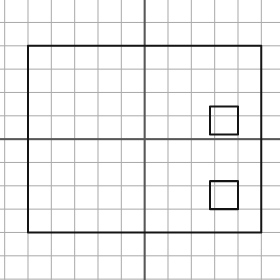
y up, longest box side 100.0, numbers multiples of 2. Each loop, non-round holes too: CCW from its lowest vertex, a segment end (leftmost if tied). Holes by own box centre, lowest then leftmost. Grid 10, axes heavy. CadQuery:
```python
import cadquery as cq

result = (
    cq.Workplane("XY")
    .moveTo(-50.0, -40.0)
    .lineTo(50.0, -40.0)
    .lineTo(50.0, 40.0)
    .lineTo(-50.0, 40.0)
    .close()
    .moveTo(28.0, -30.0)
    .lineTo(40.0, -30.0)
    .lineTo(40.0, -18.0)
    .lineTo(28.0, -18.0)
    .close()
    .moveTo(28.0, 2.0)
    .lineTo(40.0, 2.0)
    .lineTo(40.0, 14.0)
    .lineTo(28.0, 14.0)
    .close()
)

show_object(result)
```